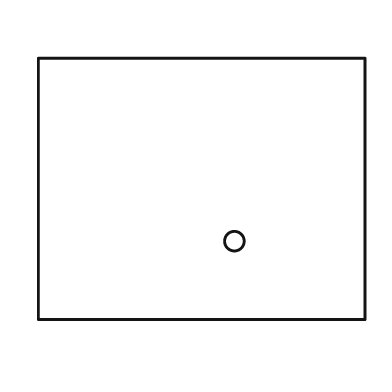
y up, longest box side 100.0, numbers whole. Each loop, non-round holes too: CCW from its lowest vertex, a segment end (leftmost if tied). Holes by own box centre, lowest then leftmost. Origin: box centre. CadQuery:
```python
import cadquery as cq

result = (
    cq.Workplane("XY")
    .moveTo(-50.0, -40.0)
    .lineTo(50.0, -40.0)
    .lineTo(50.0, 40.0)
    .lineTo(-50.0, 40.0)
    .close()
    .moveTo(10.0, -16.0)
    .circle(3.0)
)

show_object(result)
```